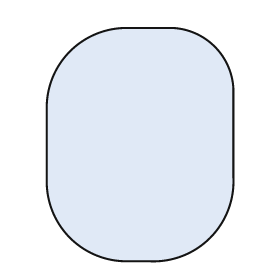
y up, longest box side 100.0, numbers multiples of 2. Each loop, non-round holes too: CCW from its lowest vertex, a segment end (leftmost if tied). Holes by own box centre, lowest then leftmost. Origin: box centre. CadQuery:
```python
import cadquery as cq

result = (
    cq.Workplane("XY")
    .moveTo(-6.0, -50.0)
    .lineTo(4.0, -50.0)
    .threePointArc((30.0, -40.0), (40.0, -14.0))
    .lineTo(40.0, 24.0)
    .threePointArc((32.0, 42.0), (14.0, 50.0))
    .lineTo(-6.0, 50.0)
    .threePointArc((-30.0, 40.0), (-40.0, 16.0))
    .lineTo(-40.0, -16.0)
    .threePointArc((-30.0, -40.0), (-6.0, -50.0))
    .close()
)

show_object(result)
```